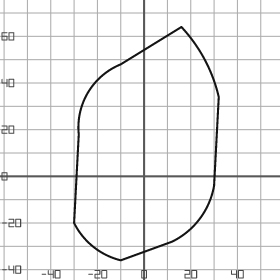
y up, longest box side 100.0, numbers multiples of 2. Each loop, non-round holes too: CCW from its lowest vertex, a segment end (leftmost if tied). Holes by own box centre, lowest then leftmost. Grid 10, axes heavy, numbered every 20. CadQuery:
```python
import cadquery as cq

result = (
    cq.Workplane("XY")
    .moveTo(-10.0, -36.0)
    .lineTo(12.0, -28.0)
    .threePointArc((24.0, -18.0), (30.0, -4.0))
    .lineTo(32.0, 34.0)
    .threePointArc((26.0, 50.0), (16.0, 64.0))
    .lineTo(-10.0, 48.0)
    .threePointArc((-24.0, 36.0), (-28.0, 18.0))
    .lineTo(-30.0, -20.0)
    .threePointArc((-22.0, -30.0), (-10.0, -36.0))
    .close()
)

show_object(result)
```